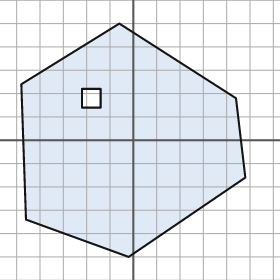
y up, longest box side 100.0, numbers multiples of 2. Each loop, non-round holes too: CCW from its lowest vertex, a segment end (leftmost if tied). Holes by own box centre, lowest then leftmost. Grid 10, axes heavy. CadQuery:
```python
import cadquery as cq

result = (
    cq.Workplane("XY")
    .moveTo(-2.0, -50.0)
    .lineTo(48.0, -16.0)
    .lineTo(44.0, 18.0)
    .lineTo(-6.0, 50.0)
    .lineTo(-48.0, 24.0)
    .lineTo(-46.0, -34.0)
    .close()
    .moveTo(-22.0, 14.0)
    .lineTo(-14.0, 14.0)
    .lineTo(-14.0, 22.0)
    .lineTo(-22.0, 22.0)
    .close()
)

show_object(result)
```